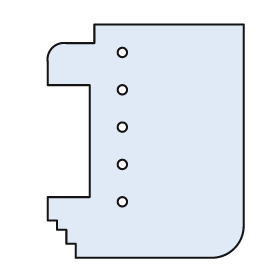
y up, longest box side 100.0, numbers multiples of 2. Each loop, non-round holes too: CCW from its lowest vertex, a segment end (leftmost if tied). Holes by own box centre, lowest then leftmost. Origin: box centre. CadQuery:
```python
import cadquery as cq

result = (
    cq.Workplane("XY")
    .moveTo(-30.0, -50.0)
    .lineTo(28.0, -50.0)
    .threePointArc((38.0, -46.0), (42.0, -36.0))
    .lineTo(42.0, 50.0)
    .lineTo(-22.0, 50.0)
    .lineTo(-22.0, 42.0)
    .lineTo(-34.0, 42.0)
    .threePointArc((-40.0, 40.0), (-42.0, 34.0))
    .lineTo(-42.0, 24.0)
    .lineTo(-24.0, 24.0)
    .lineTo(-24.0, -24.0)
    .lineTo(-42.0, -24.0)
    .lineTo(-42.0, -34.0)
    .lineTo(-38.0, -34.0)
    .lineTo(-38.0, -38.0)
    .lineTo(-34.0, -38.0)
    .lineTo(-34.0, -44.0)
    .lineTo(-30.0, -44.0)
    .close()
    .moveTo(-10.0, -26.0)
    .circle(2.0)
    .moveTo(-10.0, -10.0)
    .circle(2.0)
    .moveTo(-10.0, 6.0)
    .circle(2.0)
    .moveTo(-10.0, 22.0)
    .circle(2.0)
    .moveTo(-10.0, 38.0)
    .circle(2.0)
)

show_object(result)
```